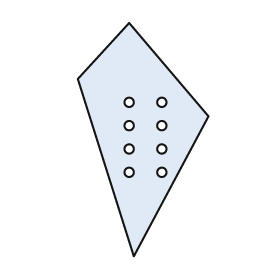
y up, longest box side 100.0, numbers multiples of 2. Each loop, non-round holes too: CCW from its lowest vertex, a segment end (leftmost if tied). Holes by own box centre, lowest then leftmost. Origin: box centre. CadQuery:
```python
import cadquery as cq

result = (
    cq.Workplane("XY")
    .moveTo(-4.0, -50.0)
    .lineTo(28.0, 10.0)
    .lineTo(-6.0, 50.0)
    .lineTo(-28.0, 26.0)
    .close()
    .moveTo(-6.0, -14.0)
    .circle(2.0)
    .moveTo(8.0, -14.0)
    .circle(2.0)
    .moveTo(-6.0, -4.0)
    .circle(2.0)
    .moveTo(8.0, -4.0)
    .circle(2.0)
    .moveTo(-6.0, 6.0)
    .circle(2.0)
    .moveTo(8.0, 6.0)
    .circle(2.0)
    .moveTo(-6.0, 16.0)
    .circle(2.0)
    .moveTo(8.0, 16.0)
    .circle(2.0)
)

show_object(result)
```